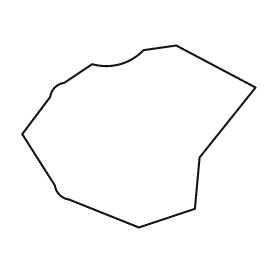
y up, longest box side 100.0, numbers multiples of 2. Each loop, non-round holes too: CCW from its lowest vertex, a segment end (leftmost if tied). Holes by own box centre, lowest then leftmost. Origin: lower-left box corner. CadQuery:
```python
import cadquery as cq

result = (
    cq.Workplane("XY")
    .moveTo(50.0, 0.0)
    .lineTo(74.0, 8.0)
    .lineTo(76.0, 30.0)
    .lineTo(100.0, 60.0)
    .lineTo(66.0, 78.0)
    .lineTo(52.0, 76.0)
    .threePointArc((42.0, 70.0), (30.0, 70.0))
    .lineTo(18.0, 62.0)
    .threePointArc((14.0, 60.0), (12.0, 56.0))
    .lineTo(0.0, 40.0)
    .lineTo(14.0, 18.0)
    .threePointArc((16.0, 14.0), (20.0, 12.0))
    .close()
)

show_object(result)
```